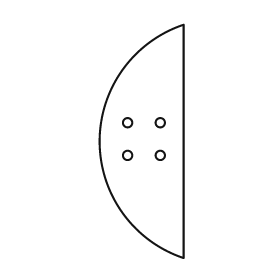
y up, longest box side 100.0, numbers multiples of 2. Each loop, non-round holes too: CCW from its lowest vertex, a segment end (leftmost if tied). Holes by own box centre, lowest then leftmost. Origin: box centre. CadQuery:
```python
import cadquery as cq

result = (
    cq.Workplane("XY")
    .moveTo(18.0, -50.0)
    .lineTo(18.0, 50.0)
    .threePointArc((-18.0, 0.0), (18.0, -50.0))
    .close()
    .moveTo(-6.0, -6.0)
    .circle(2.0)
    .moveTo(8.0, -6.0)
    .circle(2.0)
    .moveTo(-6.0, 8.0)
    .circle(2.0)
    .moveTo(8.0, 8.0)
    .circle(2.0)
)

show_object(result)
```